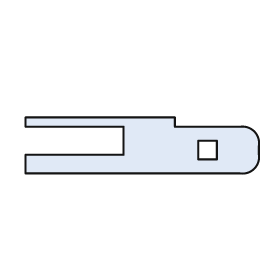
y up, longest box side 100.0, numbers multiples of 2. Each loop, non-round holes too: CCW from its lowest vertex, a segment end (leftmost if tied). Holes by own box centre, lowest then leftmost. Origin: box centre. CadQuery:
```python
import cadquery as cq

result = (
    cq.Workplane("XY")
    .moveTo(-50.0, -12.0)
    .lineTo(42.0, -12.0)
    .threePointArc((48.0, -10.0), (50.0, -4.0))
    .lineTo(50.0, 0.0)
    .threePointArc((48.0, 6.0), (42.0, 8.0))
    .lineTo(14.0, 8.0)
    .lineTo(14.0, 12.0)
    .lineTo(-50.0, 12.0)
    .lineTo(-50.0, 8.0)
    .lineTo(-8.0, 8.0)
    .lineTo(-8.0, -4.0)
    .lineTo(-50.0, -4.0)
    .close()
    .moveTo(24.0, -6.0)
    .lineTo(32.0, -6.0)
    .lineTo(32.0, 2.0)
    .lineTo(24.0, 2.0)
    .close()
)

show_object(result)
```